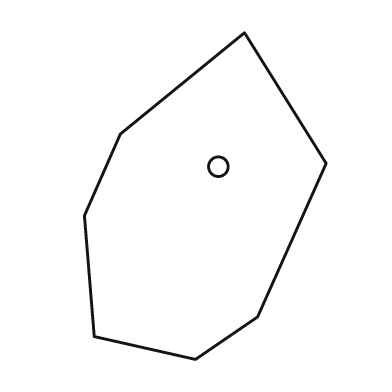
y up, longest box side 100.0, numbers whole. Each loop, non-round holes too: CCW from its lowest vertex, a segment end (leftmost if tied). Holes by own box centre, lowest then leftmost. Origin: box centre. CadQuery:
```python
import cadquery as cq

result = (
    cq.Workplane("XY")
    .moveTo(-3.0, -50.0)
    .lineTo(16.0, -37.0)
    .lineTo(37.0, 10.0)
    .lineTo(12.0, 50.0)
    .lineTo(-26.0, 19.0)
    .lineTo(-37.0, -6.0)
    .lineTo(-34.0, -43.0)
    .close()
    .moveTo(4.0, 9.0)
    .circle(3.0)
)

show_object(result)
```